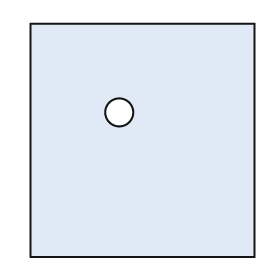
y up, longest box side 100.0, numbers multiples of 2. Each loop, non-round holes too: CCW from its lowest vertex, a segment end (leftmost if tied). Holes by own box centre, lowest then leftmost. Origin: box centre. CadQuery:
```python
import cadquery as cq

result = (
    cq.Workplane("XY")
    .moveTo(-48.0, -50.0)
    .lineTo(48.0, -50.0)
    .lineTo(48.0, 50.0)
    .lineTo(-48.0, 50.0)
    .close()
    .moveTo(-10.0, 12.0)
    .circle(6.0)
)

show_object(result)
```